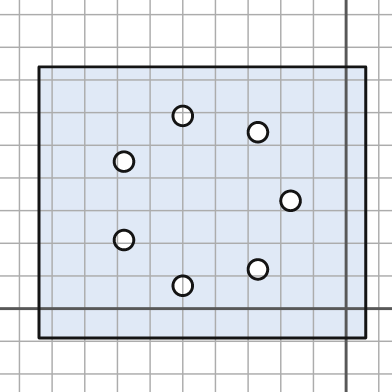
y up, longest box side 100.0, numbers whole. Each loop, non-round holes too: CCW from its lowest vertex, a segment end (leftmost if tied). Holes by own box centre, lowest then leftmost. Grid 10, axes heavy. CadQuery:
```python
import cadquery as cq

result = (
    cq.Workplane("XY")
    .moveTo(-94.0, -9.0)
    .lineTo(6.0, -9.0)
    .lineTo(6.0, 74.0)
    .lineTo(-94.0, 74.0)
    .close()
    .moveTo(-50.0, 7.0)
    .circle(3.0)
    .moveTo(-27.0, 12.0)
    .circle(3.0)
    .moveTo(-68.0, 21.0)
    .circle(3.0)
    .moveTo(-17.0, 33.0)
    .circle(3.0)
    .moveTo(-68.0, 45.0)
    .circle(3.0)
    .moveTo(-27.0, 54.0)
    .circle(3.0)
    .moveTo(-50.0, 59.0)
    .circle(3.0)
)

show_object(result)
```